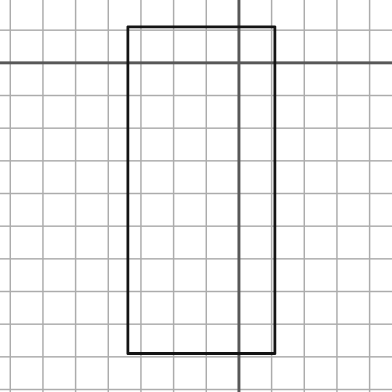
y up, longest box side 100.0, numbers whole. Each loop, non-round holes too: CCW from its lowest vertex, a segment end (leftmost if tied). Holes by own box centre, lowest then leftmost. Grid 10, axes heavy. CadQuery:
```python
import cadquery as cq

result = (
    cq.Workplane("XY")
    .moveTo(-34.0, -89.0)
    .lineTo(11.0, -89.0)
    .lineTo(11.0, 11.0)
    .lineTo(-34.0, 11.0)
    .close()
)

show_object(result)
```